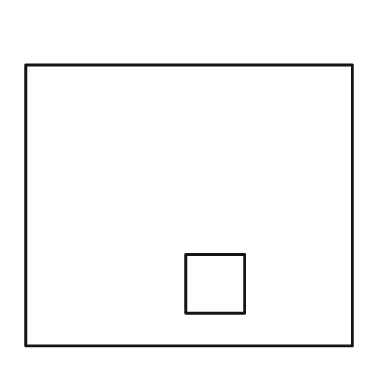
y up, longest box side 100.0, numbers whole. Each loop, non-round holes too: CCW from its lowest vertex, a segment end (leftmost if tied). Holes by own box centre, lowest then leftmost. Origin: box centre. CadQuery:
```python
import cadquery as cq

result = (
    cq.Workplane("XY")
    .moveTo(-50.0, -43.0)
    .lineTo(50.0, -43.0)
    .lineTo(50.0, 43.0)
    .lineTo(-50.0, 43.0)
    .close()
    .moveTo(-1.0, -33.0)
    .lineTo(17.0, -33.0)
    .lineTo(17.0, -15.0)
    .lineTo(-1.0, -15.0)
    .close()
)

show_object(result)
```